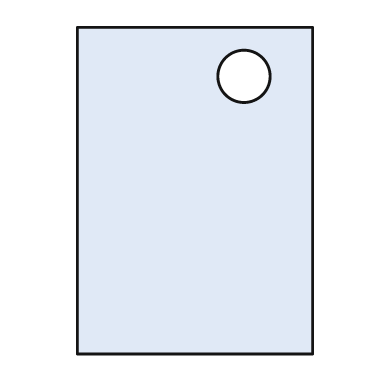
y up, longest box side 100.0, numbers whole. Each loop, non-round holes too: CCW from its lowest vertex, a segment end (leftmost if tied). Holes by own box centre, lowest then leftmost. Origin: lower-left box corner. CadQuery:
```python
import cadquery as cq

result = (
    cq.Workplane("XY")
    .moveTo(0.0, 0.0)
    .lineTo(72.0, 0.0)
    .lineTo(72.0, 100.0)
    .lineTo(0.0, 100.0)
    .close()
    .moveTo(51.0, 85.0)
    .circle(8.0)
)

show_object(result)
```